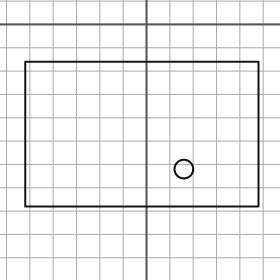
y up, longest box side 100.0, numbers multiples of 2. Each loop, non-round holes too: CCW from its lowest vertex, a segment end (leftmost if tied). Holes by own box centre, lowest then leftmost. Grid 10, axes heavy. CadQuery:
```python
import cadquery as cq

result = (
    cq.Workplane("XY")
    .moveTo(-52.0, -78.0)
    .lineTo(48.0, -78.0)
    .lineTo(48.0, -16.0)
    .lineTo(-52.0, -16.0)
    .close()
    .moveTo(16.0, -62.0)
    .circle(4.0)
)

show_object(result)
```